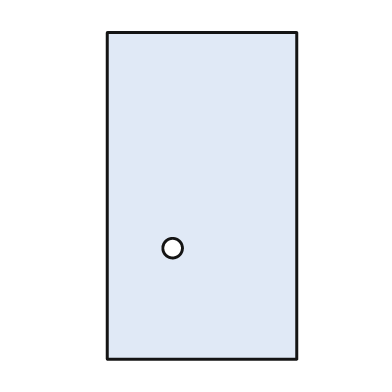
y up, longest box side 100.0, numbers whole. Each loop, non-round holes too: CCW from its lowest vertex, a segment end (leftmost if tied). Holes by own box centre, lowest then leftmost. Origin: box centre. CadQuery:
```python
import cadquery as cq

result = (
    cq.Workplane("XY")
    .moveTo(-29.0, -50.0)
    .lineTo(29.0, -50.0)
    .lineTo(29.0, 50.0)
    .lineTo(-29.0, 50.0)
    .close()
    .moveTo(-9.0, -16.0)
    .circle(3.0)
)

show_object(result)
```